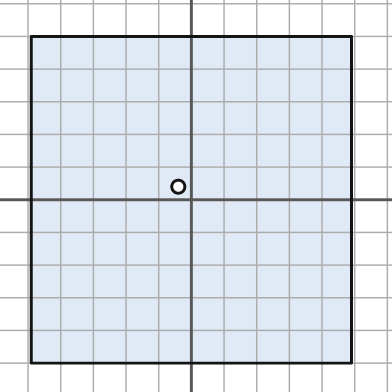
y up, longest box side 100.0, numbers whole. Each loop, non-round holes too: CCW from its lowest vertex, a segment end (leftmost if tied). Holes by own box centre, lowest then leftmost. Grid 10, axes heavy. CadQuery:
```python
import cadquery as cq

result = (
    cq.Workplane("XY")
    .moveTo(-49.0, -50.0)
    .lineTo(49.0, -50.0)
    .lineTo(49.0, 50.0)
    .lineTo(-49.0, 50.0)
    .close()
    .moveTo(-4.0, 4.0)
    .circle(2.0)
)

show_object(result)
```